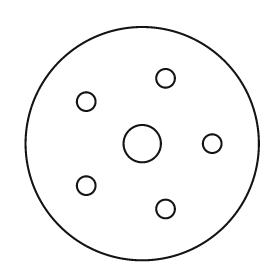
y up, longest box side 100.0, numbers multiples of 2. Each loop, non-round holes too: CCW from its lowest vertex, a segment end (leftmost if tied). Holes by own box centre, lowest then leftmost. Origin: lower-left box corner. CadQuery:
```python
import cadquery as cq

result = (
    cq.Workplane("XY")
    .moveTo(50.0, 50.0)
    .circle(50.0)
    .moveTo(60.0, 22.0)
    .circle(4.0)
    .moveTo(26.0, 32.0)
    .circle(4.0)
    .moveTo(50.0, 50.0)
    .circle(8.0)
    .moveTo(80.0, 50.0)
    .circle(4.0)
    .moveTo(26.0, 68.0)
    .circle(4.0)
    .moveTo(60.0, 78.0)
    .circle(4.0)
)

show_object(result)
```